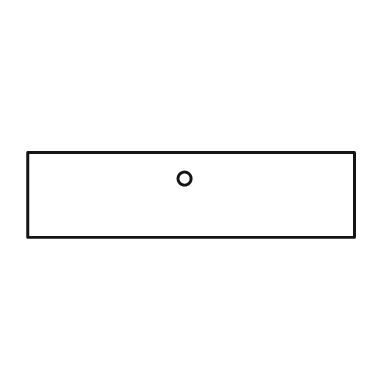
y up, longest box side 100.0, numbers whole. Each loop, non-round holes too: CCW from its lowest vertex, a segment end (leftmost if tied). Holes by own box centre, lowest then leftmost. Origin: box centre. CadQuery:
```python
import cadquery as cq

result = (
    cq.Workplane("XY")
    .moveTo(-50.0, -13.0)
    .lineTo(50.0, -13.0)
    .lineTo(50.0, 13.0)
    .lineTo(-50.0, 13.0)
    .close()
    .moveTo(-2.0, 5.0)
    .circle(2.0)
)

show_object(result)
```